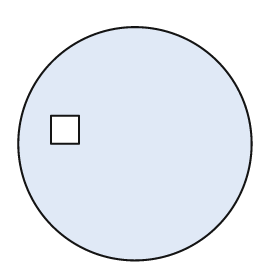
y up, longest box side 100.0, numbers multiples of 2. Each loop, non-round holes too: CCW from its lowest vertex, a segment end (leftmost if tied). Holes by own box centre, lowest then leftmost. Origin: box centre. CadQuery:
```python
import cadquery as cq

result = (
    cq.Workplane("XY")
    .moveTo(0.0, 0.0)
    .circle(50.0)
    .moveTo(-36.0, 0.0)
    .lineTo(-24.0, 0.0)
    .lineTo(-24.0, 12.0)
    .lineTo(-36.0, 12.0)
    .close()
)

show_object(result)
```